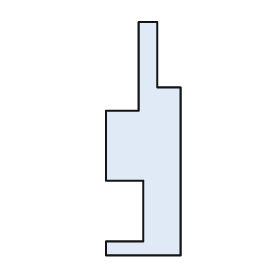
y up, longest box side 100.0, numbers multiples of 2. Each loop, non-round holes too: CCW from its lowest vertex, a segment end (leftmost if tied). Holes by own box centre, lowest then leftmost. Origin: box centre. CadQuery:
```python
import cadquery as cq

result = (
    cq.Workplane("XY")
    .moveTo(-16.0, -50.0)
    .lineTo(16.0, -50.0)
    .lineTo(16.0, 22.0)
    .lineTo(6.0, 22.0)
    .lineTo(6.0, 50.0)
    .lineTo(-2.0, 50.0)
    .lineTo(-2.0, 12.0)
    .lineTo(-16.0, 12.0)
    .lineTo(-16.0, -18.0)
    .lineTo(0.0, -18.0)
    .lineTo(0.0, -44.0)
    .lineTo(-16.0, -44.0)
    .close()
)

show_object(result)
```